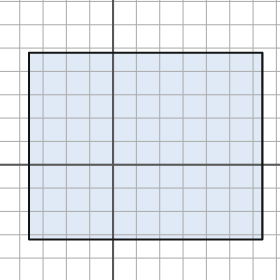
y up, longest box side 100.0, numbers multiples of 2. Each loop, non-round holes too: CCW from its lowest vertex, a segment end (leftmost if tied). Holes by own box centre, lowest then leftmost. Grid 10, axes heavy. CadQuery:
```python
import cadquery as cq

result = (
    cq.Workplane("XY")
    .moveTo(-36.0, -32.0)
    .lineTo(64.0, -32.0)
    .lineTo(64.0, 48.0)
    .lineTo(-36.0, 48.0)
    .close()
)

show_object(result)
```